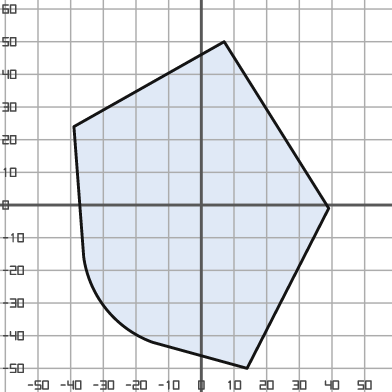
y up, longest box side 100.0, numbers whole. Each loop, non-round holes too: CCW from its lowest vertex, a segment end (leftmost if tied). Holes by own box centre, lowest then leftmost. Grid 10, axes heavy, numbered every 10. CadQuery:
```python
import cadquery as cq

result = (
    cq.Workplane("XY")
    .moveTo(14.0, -50.0)
    .lineTo(39.0, -1.0)
    .lineTo(7.0, 50.0)
    .lineTo(-39.0, 24.0)
    .lineTo(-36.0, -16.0)
    .threePointArc((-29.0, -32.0), (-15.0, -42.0))
    .close()
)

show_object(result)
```